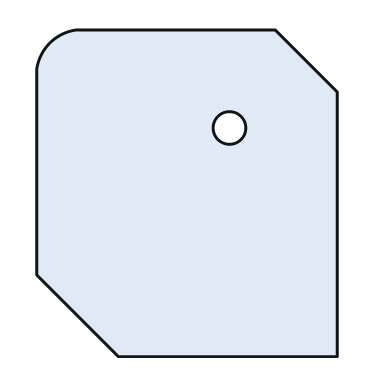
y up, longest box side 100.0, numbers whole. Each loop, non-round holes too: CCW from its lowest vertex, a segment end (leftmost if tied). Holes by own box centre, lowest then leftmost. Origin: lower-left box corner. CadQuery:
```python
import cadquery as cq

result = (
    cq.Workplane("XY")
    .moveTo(25.0, 0.0)
    .lineTo(92.0, 0.0)
    .lineTo(92.0, 81.0)
    .lineTo(73.0, 100.0)
    .lineTo(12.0, 100.0)
    .threePointArc((4.0, 96.0), (0.0, 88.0))
    .lineTo(0.0, 25.0)
    .close()
    .moveTo(59.0, 70.0)
    .circle(5.0)
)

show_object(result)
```